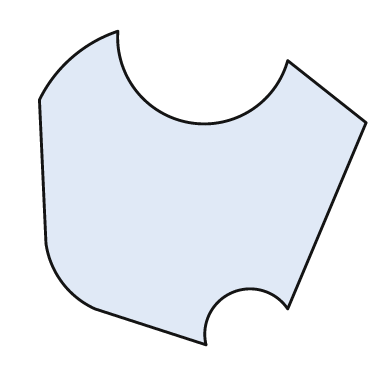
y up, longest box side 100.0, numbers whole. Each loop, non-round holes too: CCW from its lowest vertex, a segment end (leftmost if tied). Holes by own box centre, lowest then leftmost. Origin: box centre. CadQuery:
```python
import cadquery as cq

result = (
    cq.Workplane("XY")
    .moveTo(1.0, -48.0)
    .threePointArc((9.0, -32.0), (26.0, -37.0))
    .lineTo(50.0, 20.0)
    .lineTo(26.0, 39.0)
    .threePointArc((-4.0, 20.0), (-26.0, 48.0))
    .threePointArc((-40.0, 40.0), (-50.0, 27.0))
    .lineTo(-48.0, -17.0)
    .threePointArc((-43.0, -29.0), (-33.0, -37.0))
    .close()
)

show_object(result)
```